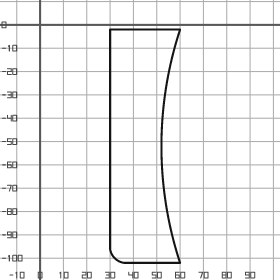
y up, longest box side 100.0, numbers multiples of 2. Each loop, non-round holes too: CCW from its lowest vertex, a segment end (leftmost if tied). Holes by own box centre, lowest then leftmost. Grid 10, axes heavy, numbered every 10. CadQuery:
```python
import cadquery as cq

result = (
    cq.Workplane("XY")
    .moveTo(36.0, -102.0)
    .lineTo(60.0, -102.0)
    .threePointArc((52.0, -52.0), (60.0, -2.0))
    .lineTo(30.0, -2.0)
    .lineTo(30.0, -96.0)
    .threePointArc((32.0, -100.0), (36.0, -102.0))
    .close()
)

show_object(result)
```